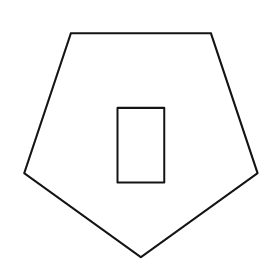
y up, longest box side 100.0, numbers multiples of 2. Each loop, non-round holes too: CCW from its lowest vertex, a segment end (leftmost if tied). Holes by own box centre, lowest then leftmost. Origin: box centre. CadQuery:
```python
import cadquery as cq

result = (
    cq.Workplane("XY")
    .moveTo(0.0, -48.0)
    .lineTo(50.0, -12.0)
    .lineTo(30.0, 48.0)
    .lineTo(-30.0, 48.0)
    .lineTo(-50.0, -12.0)
    .close()
    .moveTo(-10.0, -16.0)
    .lineTo(10.0, -16.0)
    .lineTo(10.0, 16.0)
    .lineTo(-10.0, 16.0)
    .close()
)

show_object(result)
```